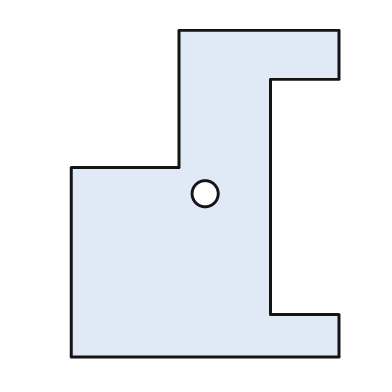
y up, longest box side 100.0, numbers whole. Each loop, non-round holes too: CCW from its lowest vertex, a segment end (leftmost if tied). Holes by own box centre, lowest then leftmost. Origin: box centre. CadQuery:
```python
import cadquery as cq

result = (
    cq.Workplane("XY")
    .moveTo(-41.0, -50.0)
    .lineTo(41.0, -50.0)
    .lineTo(41.0, -37.0)
    .lineTo(20.0, -37.0)
    .lineTo(20.0, 35.0)
    .lineTo(41.0, 35.0)
    .lineTo(41.0, 50.0)
    .lineTo(-8.0, 50.0)
    .lineTo(-8.0, 8.0)
    .lineTo(-41.0, 8.0)
    .close()
    .moveTo(0.0, 0.0)
    .circle(4.0)
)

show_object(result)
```